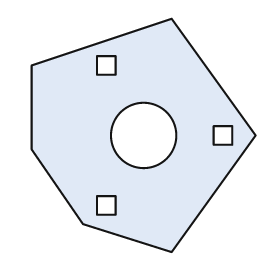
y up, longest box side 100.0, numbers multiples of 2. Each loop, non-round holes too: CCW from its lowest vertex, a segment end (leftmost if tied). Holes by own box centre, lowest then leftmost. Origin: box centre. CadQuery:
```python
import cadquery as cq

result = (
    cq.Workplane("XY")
    .moveTo(12.0, -50.0)
    .lineTo(48.0, 0.0)
    .lineTo(12.0, 50.0)
    .lineTo(-48.0, 30.0)
    .lineTo(-48.0, -6.0)
    .lineTo(-26.0, -38.0)
    .close()
    .moveTo(-20.0, -34.0)
    .lineTo(-12.0, -34.0)
    .lineTo(-12.0, -26.0)
    .lineTo(-20.0, -26.0)
    .close()
    .moveTo(0.0, 0.0)
    .circle(14.0)
    .moveTo(30.0, -4.0)
    .lineTo(38.0, -4.0)
    .lineTo(38.0, 4.0)
    .lineTo(30.0, 4.0)
    .close()
    .moveTo(-20.0, 26.0)
    .lineTo(-12.0, 26.0)
    .lineTo(-12.0, 34.0)
    .lineTo(-20.0, 34.0)
    .close()
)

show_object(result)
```